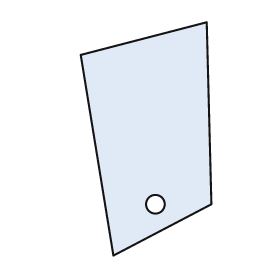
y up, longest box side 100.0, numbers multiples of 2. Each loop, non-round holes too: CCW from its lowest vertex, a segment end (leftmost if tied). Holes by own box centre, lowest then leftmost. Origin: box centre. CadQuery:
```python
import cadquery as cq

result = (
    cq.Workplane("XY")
    .moveTo(-14.0, -50.0)
    .lineTo(28.0, -28.0)
    .lineTo(26.0, 50.0)
    .lineTo(-28.0, 36.0)
    .close()
    .moveTo(4.0, -28.0)
    .circle(4.0)
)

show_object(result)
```